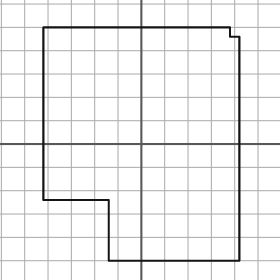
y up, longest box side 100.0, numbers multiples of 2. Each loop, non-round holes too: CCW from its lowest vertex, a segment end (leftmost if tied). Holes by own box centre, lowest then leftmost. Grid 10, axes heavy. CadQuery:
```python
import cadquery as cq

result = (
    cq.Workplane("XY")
    .moveTo(-14.0, -50.0)
    .lineTo(42.0, -50.0)
    .lineTo(42.0, 46.0)
    .lineTo(38.0, 46.0)
    .lineTo(38.0, 50.0)
    .lineTo(-42.0, 50.0)
    .lineTo(-42.0, -24.0)
    .lineTo(-14.0, -24.0)
    .close()
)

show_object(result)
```